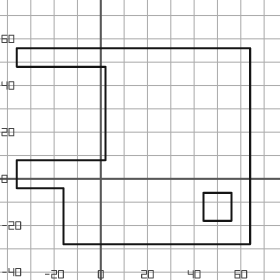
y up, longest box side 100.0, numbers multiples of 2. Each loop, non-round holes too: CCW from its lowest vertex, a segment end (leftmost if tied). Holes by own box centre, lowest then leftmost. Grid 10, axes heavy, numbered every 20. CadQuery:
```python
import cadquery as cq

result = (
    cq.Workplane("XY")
    .moveTo(-16.0, -28.0)
    .lineTo(64.0, -28.0)
    .lineTo(64.0, 56.0)
    .lineTo(-36.0, 56.0)
    .lineTo(-36.0, 48.0)
    .lineTo(2.0, 48.0)
    .lineTo(2.0, 8.0)
    .lineTo(-36.0, 8.0)
    .lineTo(-36.0, -4.0)
    .lineTo(-16.0, -4.0)
    .close()
    .moveTo(44.0, -18.0)
    .lineTo(56.0, -18.0)
    .lineTo(56.0, -6.0)
    .lineTo(44.0, -6.0)
    .close()
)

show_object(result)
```